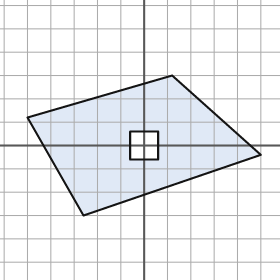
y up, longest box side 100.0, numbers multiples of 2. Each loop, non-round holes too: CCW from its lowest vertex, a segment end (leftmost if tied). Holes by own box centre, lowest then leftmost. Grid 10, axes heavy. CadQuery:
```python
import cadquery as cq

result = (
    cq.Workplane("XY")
    .moveTo(-26.0, -30.0)
    .lineTo(50.0, -4.0)
    .lineTo(12.0, 30.0)
    .lineTo(-50.0, 12.0)
    .close()
    .moveTo(-6.0, -6.0)
    .lineTo(6.0, -6.0)
    .lineTo(6.0, 6.0)
    .lineTo(-6.0, 6.0)
    .close()
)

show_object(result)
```